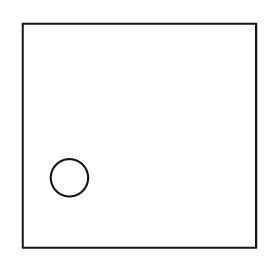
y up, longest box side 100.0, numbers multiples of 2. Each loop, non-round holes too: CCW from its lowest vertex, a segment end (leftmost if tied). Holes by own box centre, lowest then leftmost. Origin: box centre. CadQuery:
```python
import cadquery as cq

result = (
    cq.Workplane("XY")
    .moveTo(-50.0, -48.0)
    .lineTo(50.0, -48.0)
    .lineTo(50.0, 48.0)
    .lineTo(-50.0, 48.0)
    .close()
    .moveTo(-30.0, -18.0)
    .circle(8.0)
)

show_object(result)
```